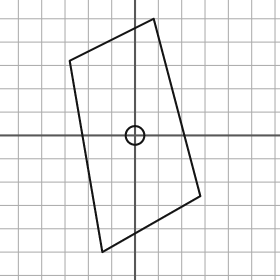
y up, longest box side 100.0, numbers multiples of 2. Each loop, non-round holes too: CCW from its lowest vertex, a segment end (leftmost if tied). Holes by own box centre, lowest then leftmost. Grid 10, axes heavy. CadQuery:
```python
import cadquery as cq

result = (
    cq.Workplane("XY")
    .moveTo(-14.0, -50.0)
    .lineTo(28.0, -26.0)
    .lineTo(8.0, 50.0)
    .lineTo(-28.0, 32.0)
    .close()
    .moveTo(0.0, 0.0)
    .circle(4.0)
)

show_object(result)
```